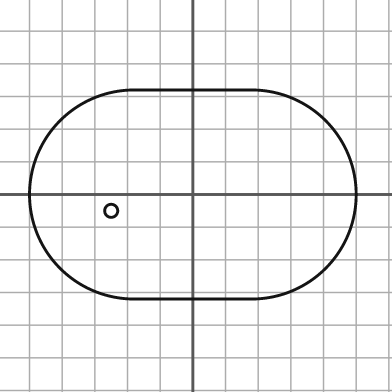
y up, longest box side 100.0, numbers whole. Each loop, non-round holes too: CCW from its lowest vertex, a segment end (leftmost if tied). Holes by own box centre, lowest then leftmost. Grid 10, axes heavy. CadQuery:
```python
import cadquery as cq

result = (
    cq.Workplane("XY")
    .moveTo(-18.0, -32.0)
    .lineTo(18.0, -32.0)
    .threePointArc((50.0, 0.0), (18.0, 32.0))
    .lineTo(-18.0, 32.0)
    .threePointArc((-50.0, 0.0), (-18.0, -32.0))
    .close()
    .moveTo(-25.0, -5.0)
    .circle(2.0)
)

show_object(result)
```